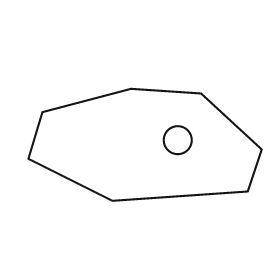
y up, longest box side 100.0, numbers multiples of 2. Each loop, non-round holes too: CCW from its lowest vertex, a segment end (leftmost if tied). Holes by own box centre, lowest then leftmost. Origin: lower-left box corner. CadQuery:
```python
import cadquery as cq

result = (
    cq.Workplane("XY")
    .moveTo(36.0, 0.0)
    .lineTo(94.0, 4.0)
    .lineTo(100.0, 22.0)
    .lineTo(74.0, 46.0)
    .lineTo(44.0, 48.0)
    .lineTo(6.0, 38.0)
    .lineTo(0.0, 18.0)
    .close()
    .moveTo(64.0, 26.0)
    .circle(6.0)
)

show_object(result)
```